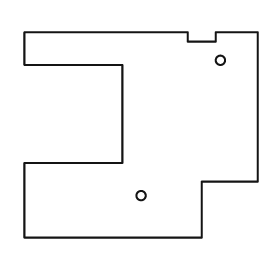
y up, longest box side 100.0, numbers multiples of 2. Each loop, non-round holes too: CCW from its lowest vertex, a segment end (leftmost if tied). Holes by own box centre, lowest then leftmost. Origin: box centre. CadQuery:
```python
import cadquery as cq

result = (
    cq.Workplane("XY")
    .moveTo(-50.0, -44.0)
    .lineTo(26.0, -44.0)
    .lineTo(26.0, -20.0)
    .lineTo(50.0, -20.0)
    .lineTo(50.0, 44.0)
    .lineTo(32.0, 44.0)
    .lineTo(32.0, 40.0)
    .lineTo(20.0, 40.0)
    .lineTo(20.0, 44.0)
    .lineTo(-50.0, 44.0)
    .lineTo(-50.0, 30.0)
    .lineTo(-8.0, 30.0)
    .lineTo(-8.0, -12.0)
    .lineTo(-50.0, -12.0)
    .close()
    .moveTo(0.0, -26.0)
    .circle(2.0)
    .moveTo(34.0, 32.0)
    .circle(2.0)
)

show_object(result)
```